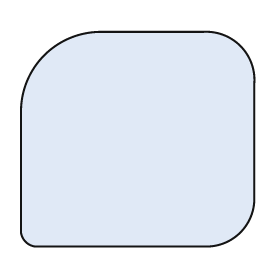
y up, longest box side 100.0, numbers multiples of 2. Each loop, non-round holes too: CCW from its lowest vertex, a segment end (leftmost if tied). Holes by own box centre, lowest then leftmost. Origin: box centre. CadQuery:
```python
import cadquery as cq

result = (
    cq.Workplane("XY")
    .moveTo(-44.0, -46.0)
    .lineTo(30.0, -46.0)
    .threePointArc((44.0, -40.0), (50.0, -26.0))
    .lineTo(50.0, 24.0)
    .threePointArc((44.0, 40.0), (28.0, 46.0))
    .lineTo(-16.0, 46.0)
    .threePointArc((-40.0, 36.0), (-50.0, 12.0))
    .lineTo(-50.0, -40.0)
    .threePointArc((-48.0, -44.0), (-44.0, -46.0))
    .close()
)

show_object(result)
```